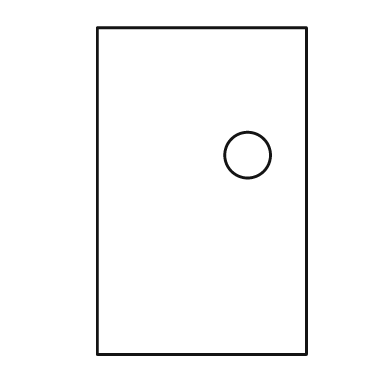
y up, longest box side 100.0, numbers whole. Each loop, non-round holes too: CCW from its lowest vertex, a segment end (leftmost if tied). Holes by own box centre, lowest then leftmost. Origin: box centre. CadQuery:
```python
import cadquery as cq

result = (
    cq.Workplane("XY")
    .moveTo(-32.0, -50.0)
    .lineTo(32.0, -50.0)
    .lineTo(32.0, 50.0)
    .lineTo(-32.0, 50.0)
    .close()
    .moveTo(14.0, 11.0)
    .circle(7.0)
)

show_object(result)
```